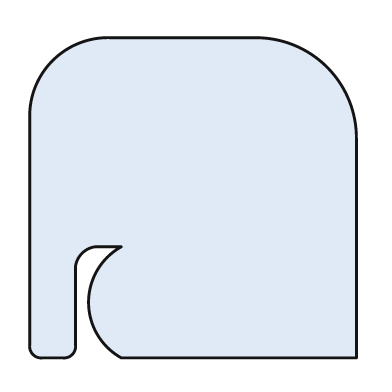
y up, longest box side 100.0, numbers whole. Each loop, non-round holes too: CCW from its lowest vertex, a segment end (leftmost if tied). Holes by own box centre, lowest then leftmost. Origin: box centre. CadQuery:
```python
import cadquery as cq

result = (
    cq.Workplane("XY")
    .moveTo(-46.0, -49.0)
    .lineTo(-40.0, -49.0)
    .threePointArc((-37.0, -48.0), (-36.0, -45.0))
    .lineTo(-36.0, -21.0)
    .threePointArc((-34.0, -17.0), (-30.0, -15.0))
    .lineTo(-22.0, -15.0)
    .threePointArc((-32.0, -32.0), (-22.0, -49.0))
    .lineTo(50.0, -49.0)
    .lineTo(50.0, 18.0)
    .threePointArc((41.0, 40.0), (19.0, 49.0))
    .lineTo(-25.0, 49.0)
    .threePointArc((-43.0, 42.0), (-50.0, 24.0))
    .lineTo(-50.0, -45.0)
    .threePointArc((-49.0, -48.0), (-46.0, -49.0))
    .close()
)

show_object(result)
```